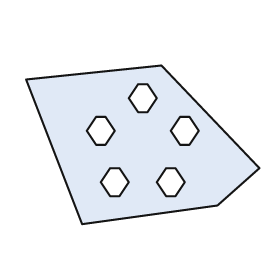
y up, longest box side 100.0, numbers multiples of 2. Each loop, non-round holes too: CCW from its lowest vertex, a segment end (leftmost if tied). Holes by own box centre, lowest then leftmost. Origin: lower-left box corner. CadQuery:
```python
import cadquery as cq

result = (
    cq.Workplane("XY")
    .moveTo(24.0, 0.0)
    .lineTo(82.0, 8.0)
    .lineTo(100.0, 24.0)
    .lineTo(58.0, 68.0)
    .lineTo(0.0, 62.0)
    .close()
    .moveTo(36.0, 12.0)
    .lineTo(40.0, 12.0)
    .lineTo(44.0, 18.0)
    .lineTo(40.0, 24.0)
    .lineTo(36.0, 24.0)
    .lineTo(32.0, 18.0)
    .close()
    .moveTo(60.0, 12.0)
    .lineTo(64.0, 12.0)
    .lineTo(68.0, 18.0)
    .lineTo(64.0, 24.0)
    .lineTo(60.0, 24.0)
    .lineTo(56.0, 18.0)
    .close()
    .moveTo(30.0, 34.0)
    .lineTo(34.0, 34.0)
    .lineTo(38.0, 40.0)
    .lineTo(34.0, 46.0)
    .lineTo(30.0, 46.0)
    .lineTo(26.0, 40.0)
    .close()
    .moveTo(66.0, 34.0)
    .lineTo(70.0, 34.0)
    .lineTo(74.0, 40.0)
    .lineTo(70.0, 46.0)
    .lineTo(66.0, 46.0)
    .lineTo(62.0, 40.0)
    .close()
    .moveTo(48.0, 48.0)
    .lineTo(52.0, 48.0)
    .lineTo(56.0, 54.0)
    .lineTo(52.0, 60.0)
    .lineTo(48.0, 60.0)
    .lineTo(44.0, 54.0)
    .close()
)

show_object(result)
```